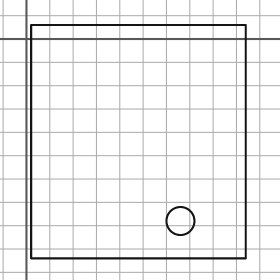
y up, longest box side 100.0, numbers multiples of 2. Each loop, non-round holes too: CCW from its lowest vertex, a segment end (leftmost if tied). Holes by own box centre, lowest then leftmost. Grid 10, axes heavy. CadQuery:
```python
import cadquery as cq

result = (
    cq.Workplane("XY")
    .moveTo(2.0, -94.0)
    .lineTo(94.0, -94.0)
    .lineTo(94.0, 6.0)
    .lineTo(2.0, 6.0)
    .close()
    .moveTo(66.0, -78.0)
    .circle(6.0)
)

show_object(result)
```